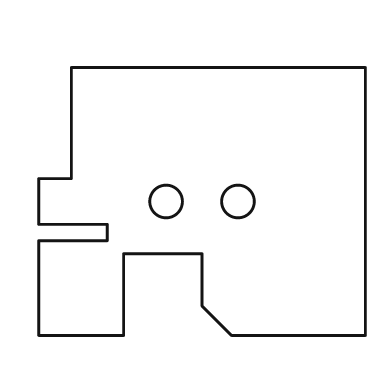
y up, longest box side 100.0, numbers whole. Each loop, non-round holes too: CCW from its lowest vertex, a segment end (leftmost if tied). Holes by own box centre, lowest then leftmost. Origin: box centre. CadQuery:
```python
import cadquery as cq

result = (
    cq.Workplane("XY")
    .moveTo(-50.0, -41.0)
    .lineTo(-24.0, -41.0)
    .lineTo(-24.0, -16.0)
    .lineTo(0.0, -16.0)
    .lineTo(0.0, -32.0)
    .lineTo(9.0, -41.0)
    .lineTo(50.0, -41.0)
    .lineTo(50.0, 41.0)
    .lineTo(-40.0, 41.0)
    .lineTo(-40.0, 7.0)
    .lineTo(-50.0, 7.0)
    .lineTo(-50.0, -7.0)
    .lineTo(-29.0, -7.0)
    .lineTo(-29.0, -12.0)
    .lineTo(-50.0, -12.0)
    .close()
    .moveTo(-11.0, 0.0)
    .circle(5.0)
    .moveTo(11.0, 0.0)
    .circle(5.0)
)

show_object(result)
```